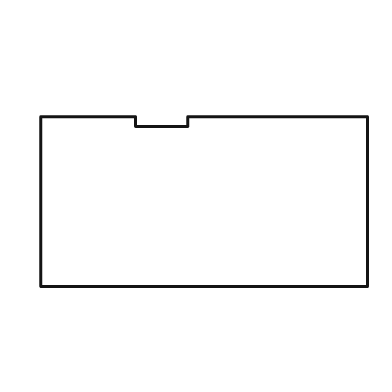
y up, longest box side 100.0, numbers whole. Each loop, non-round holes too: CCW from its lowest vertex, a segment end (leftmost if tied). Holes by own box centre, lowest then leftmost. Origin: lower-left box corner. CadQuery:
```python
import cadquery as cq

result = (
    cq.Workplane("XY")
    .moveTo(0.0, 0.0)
    .lineTo(100.0, 0.0)
    .lineTo(100.0, 52.0)
    .lineTo(45.0, 52.0)
    .lineTo(45.0, 49.0)
    .lineTo(29.0, 49.0)
    .lineTo(29.0, 52.0)
    .lineTo(0.0, 52.0)
    .close()
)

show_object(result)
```